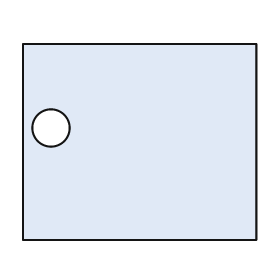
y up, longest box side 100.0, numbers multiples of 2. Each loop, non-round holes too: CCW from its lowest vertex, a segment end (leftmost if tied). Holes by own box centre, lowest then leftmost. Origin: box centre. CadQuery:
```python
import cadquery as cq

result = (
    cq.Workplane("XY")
    .moveTo(-50.0, -42.0)
    .lineTo(50.0, -42.0)
    .lineTo(50.0, 42.0)
    .lineTo(-50.0, 42.0)
    .close()
    .moveTo(-38.0, 6.0)
    .circle(8.0)
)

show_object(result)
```